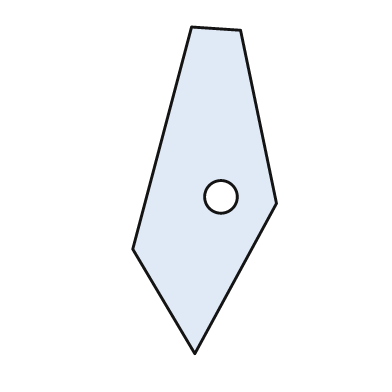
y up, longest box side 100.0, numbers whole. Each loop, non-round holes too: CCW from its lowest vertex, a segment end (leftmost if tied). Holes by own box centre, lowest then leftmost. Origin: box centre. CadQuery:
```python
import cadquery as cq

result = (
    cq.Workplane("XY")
    .moveTo(-3.0, -50.0)
    .lineTo(22.0, -4.0)
    .lineTo(11.0, 49.0)
    .lineTo(-4.0, 50.0)
    .lineTo(-22.0, -18.0)
    .close()
    .moveTo(5.0, -2.0)
    .circle(5.0)
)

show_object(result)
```